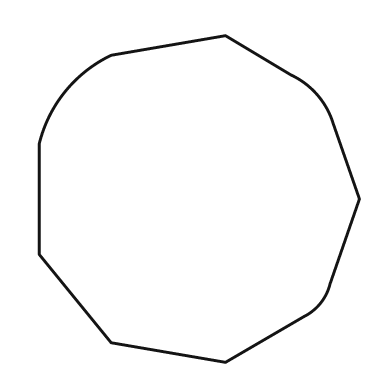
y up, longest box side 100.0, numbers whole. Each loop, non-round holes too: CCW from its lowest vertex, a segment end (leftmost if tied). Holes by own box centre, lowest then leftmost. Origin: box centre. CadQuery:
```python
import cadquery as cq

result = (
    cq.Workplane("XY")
    .moveTo(8.0, -50.0)
    .lineTo(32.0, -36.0)
    .threePointArc((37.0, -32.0), (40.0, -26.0))
    .lineTo(49.0, 0.0)
    .lineTo(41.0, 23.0)
    .threePointArc((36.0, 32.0), (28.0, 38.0))
    .lineTo(8.0, 50.0)
    .lineTo(-27.0, 44.0)
    .threePointArc((-41.0, 33.0), (-49.0, 17.0))
    .lineTo(-49.0, -17.0)
    .lineTo(-27.0, -44.0)
    .close()
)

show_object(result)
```